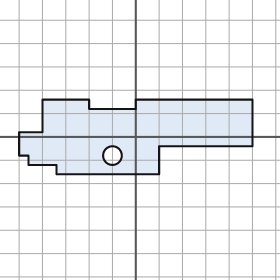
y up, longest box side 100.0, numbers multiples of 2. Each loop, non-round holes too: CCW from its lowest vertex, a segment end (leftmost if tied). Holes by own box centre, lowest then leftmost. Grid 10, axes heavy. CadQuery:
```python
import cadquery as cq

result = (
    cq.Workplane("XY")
    .moveTo(-34.0, -16.0)
    .lineTo(10.0, -16.0)
    .lineTo(10.0, -4.0)
    .lineTo(50.0, -4.0)
    .lineTo(50.0, 16.0)
    .lineTo(0.0, 16.0)
    .lineTo(0.0, 12.0)
    .lineTo(-20.0, 12.0)
    .lineTo(-20.0, 16.0)
    .lineTo(-40.0, 16.0)
    .lineTo(-40.0, 2.0)
    .lineTo(-50.0, 2.0)
    .lineTo(-50.0, -8.0)
    .lineTo(-46.0, -8.0)
    .lineTo(-46.0, -12.0)
    .lineTo(-34.0, -12.0)
    .close()
    .moveTo(-10.0, -8.0)
    .circle(4.0)
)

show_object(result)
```